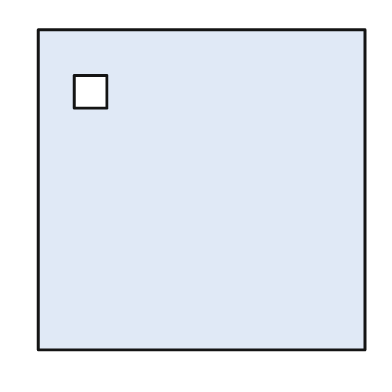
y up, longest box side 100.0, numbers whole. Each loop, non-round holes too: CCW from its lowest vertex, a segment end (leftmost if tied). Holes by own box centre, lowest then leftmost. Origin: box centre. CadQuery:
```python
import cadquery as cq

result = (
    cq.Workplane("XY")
    .moveTo(-50.0, -49.0)
    .lineTo(50.0, -49.0)
    .lineTo(50.0, 49.0)
    .lineTo(-50.0, 49.0)
    .close()
    .moveTo(-39.0, 25.0)
    .lineTo(-29.0, 25.0)
    .lineTo(-29.0, 35.0)
    .lineTo(-39.0, 35.0)
    .close()
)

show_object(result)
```